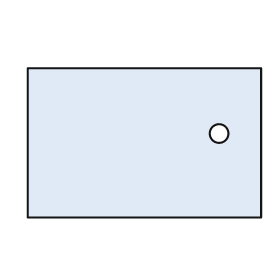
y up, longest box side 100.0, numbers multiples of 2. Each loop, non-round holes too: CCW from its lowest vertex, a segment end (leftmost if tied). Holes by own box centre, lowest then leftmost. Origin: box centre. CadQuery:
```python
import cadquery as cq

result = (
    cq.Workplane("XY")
    .moveTo(-50.0, -32.0)
    .lineTo(50.0, -32.0)
    .lineTo(50.0, 32.0)
    .lineTo(-50.0, 32.0)
    .close()
    .moveTo(32.0, 4.0)
    .circle(4.0)
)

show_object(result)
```